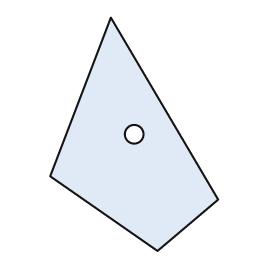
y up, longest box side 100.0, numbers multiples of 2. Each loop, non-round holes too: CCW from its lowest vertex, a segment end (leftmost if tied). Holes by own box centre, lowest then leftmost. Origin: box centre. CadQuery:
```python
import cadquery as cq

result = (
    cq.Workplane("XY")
    .moveTo(10.0, -50.0)
    .lineTo(36.0, -28.0)
    .lineTo(-10.0, 50.0)
    .lineTo(-36.0, -18.0)
    .close()
    .moveTo(0.0, 0.0)
    .circle(4.0)
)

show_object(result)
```